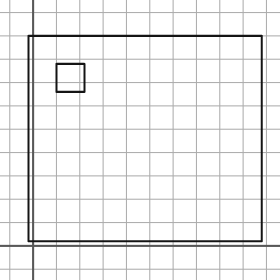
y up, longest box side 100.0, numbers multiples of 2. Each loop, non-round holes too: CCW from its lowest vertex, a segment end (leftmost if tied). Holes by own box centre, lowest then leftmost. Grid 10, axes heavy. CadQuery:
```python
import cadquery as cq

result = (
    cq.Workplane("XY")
    .moveTo(-2.0, 2.0)
    .lineTo(98.0, 2.0)
    .lineTo(98.0, 90.0)
    .lineTo(-2.0, 90.0)
    .close()
    .moveTo(10.0, 66.0)
    .lineTo(22.0, 66.0)
    .lineTo(22.0, 78.0)
    .lineTo(10.0, 78.0)
    .close()
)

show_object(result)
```